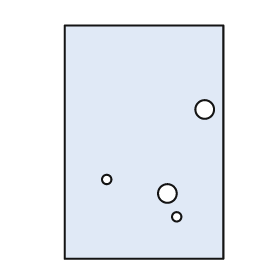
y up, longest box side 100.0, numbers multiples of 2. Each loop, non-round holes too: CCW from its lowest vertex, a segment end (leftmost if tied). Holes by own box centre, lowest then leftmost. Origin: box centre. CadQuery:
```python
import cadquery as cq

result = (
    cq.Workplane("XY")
    .moveTo(-34.0, -50.0)
    .lineTo(34.0, -50.0)
    .lineTo(34.0, 50.0)
    .lineTo(-34.0, 50.0)
    .close()
    .moveTo(14.0, -32.0)
    .circle(2.0)
    .moveTo(10.0, -22.0)
    .circle(4.0)
    .moveTo(-16.0, -16.0)
    .circle(2.0)
    .moveTo(26.0, 14.0)
    .circle(4.0)
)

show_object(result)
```